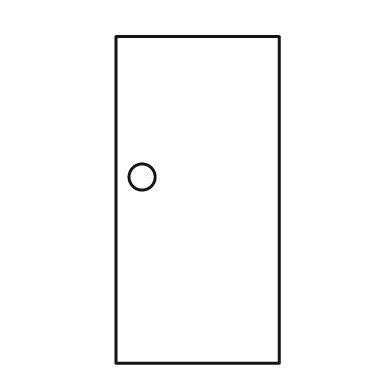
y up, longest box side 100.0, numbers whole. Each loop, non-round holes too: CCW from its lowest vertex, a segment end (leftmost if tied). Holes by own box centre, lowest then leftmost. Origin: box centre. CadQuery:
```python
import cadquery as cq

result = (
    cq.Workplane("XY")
    .moveTo(-25.0, -50.0)
    .lineTo(25.0, -50.0)
    .lineTo(25.0, 50.0)
    .lineTo(-25.0, 50.0)
    .close()
    .moveTo(-17.0, 7.0)
    .circle(4.0)
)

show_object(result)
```